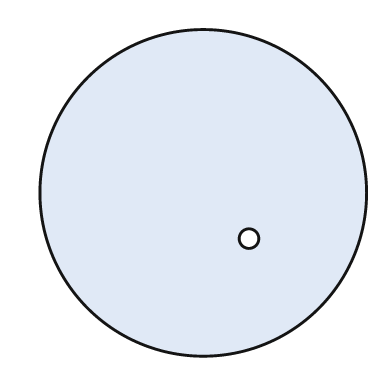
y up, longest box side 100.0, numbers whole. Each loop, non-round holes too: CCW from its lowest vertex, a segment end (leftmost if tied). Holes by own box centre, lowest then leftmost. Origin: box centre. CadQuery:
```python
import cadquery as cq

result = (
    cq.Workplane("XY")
    .moveTo(0.0, 0.0)
    .circle(50.0)
    .moveTo(14.0, -14.0)
    .circle(3.0)
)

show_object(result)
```